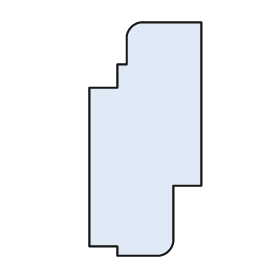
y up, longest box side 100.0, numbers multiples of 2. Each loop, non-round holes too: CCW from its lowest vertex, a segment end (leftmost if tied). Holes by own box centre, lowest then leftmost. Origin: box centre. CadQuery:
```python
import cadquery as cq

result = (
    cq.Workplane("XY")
    .moveTo(-12.0, -50.0)
    .lineTo(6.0, -50.0)
    .threePointArc((10.0, -48.0), (12.0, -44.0))
    .lineTo(12.0, -20.0)
    .lineTo(24.0, -20.0)
    .lineTo(24.0, 50.0)
    .lineTo(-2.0, 50.0)
    .threePointArc((-6.0, 48.0), (-8.0, 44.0))
    .lineTo(-8.0, 32.0)
    .lineTo(-12.0, 32.0)
    .lineTo(-12.0, 22.0)
    .lineTo(-24.0, 22.0)
    .lineTo(-24.0, -46.0)
    .lineTo(-12.0, -46.0)
    .close()
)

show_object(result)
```